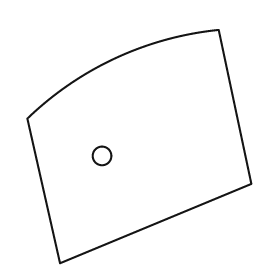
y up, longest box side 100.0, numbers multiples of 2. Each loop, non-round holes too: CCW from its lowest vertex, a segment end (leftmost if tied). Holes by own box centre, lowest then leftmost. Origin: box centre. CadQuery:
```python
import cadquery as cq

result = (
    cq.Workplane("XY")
    .moveTo(-34.0, -50.0)
    .lineTo(48.0, -16.0)
    .lineTo(34.0, 50.0)
    .threePointArc((-10.0, 38.0), (-48.0, 12.0))
    .close()
    .moveTo(-16.0, -4.0)
    .circle(4.0)
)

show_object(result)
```